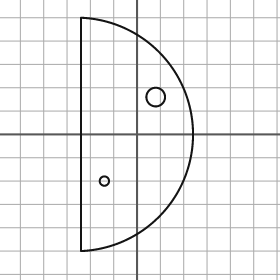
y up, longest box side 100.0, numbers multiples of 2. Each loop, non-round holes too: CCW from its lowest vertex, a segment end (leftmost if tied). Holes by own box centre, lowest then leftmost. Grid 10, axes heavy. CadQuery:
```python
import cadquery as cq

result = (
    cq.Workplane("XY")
    .moveTo(-24.0, -50.0)
    .threePointArc((24.0, 0.0), (-24.0, 50.0))
    .close()
    .moveTo(-14.0, -20.0)
    .circle(2.0)
    .moveTo(8.0, 16.0)
    .circle(4.0)
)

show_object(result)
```